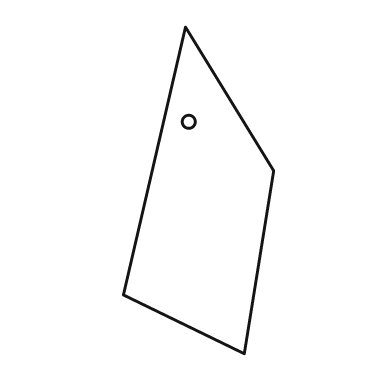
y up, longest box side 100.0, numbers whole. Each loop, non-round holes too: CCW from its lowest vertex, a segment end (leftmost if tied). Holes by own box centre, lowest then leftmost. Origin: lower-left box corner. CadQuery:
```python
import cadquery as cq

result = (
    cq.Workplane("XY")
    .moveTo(37.0, 0.0)
    .lineTo(46.0, 56.0)
    .lineTo(19.0, 100.0)
    .lineTo(0.0, 18.0)
    .close()
    .moveTo(20.0, 71.0)
    .circle(2.0)
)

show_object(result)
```